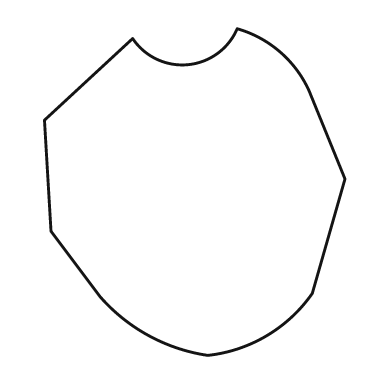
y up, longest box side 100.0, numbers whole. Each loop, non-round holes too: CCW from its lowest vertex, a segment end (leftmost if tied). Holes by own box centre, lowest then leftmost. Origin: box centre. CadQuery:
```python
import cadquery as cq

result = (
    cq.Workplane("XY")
    .moveTo(4.0, -50.0)
    .threePointArc((22.0, -44.0), (36.0, -31.0))
    .lineTo(46.0, 4.0)
    .lineTo(35.0, 31.0)
    .threePointArc((26.0, 43.0), (13.0, 50.0))
    .threePointArc((-2.0, 39.0), (-19.0, 47.0))
    .lineTo(-46.0, 22.0)
    .lineTo(-44.0, -12.0)
    .lineTo(-29.0, -32.0)
    .threePointArc((-14.0, -44.0), (4.0, -50.0))
    .close()
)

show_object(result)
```